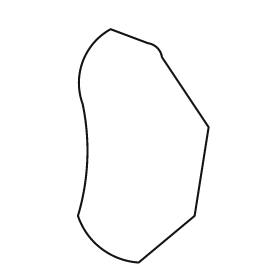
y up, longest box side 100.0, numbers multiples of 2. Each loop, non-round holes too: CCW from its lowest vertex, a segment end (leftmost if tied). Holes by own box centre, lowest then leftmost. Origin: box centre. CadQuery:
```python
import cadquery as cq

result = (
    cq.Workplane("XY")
    .moveTo(-2.0, -50.0)
    .lineTo(22.0, -30.0)
    .lineTo(28.0, 8.0)
    .lineTo(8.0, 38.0)
    .threePointArc((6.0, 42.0), (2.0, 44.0))
    .lineTo(-14.0, 50.0)
    .threePointArc((-26.0, 36.0), (-26.0, 18.0))
    .threePointArc((-24.0, -6.0), (-28.0, -30.0))
    .threePointArc((-18.0, -44.0), (-2.0, -50.0))
    .close()
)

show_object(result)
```